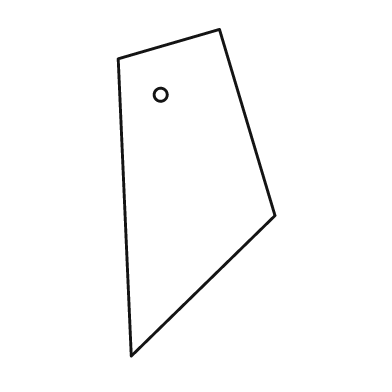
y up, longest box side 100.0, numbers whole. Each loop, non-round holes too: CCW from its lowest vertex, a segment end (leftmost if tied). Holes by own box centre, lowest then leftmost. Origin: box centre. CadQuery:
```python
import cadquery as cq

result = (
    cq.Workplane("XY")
    .moveTo(-20.0, -50.0)
    .lineTo(24.0, -7.0)
    .lineTo(7.0, 50.0)
    .lineTo(-24.0, 41.0)
    .close()
    .moveTo(-11.0, 30.0)
    .circle(2.0)
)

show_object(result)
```